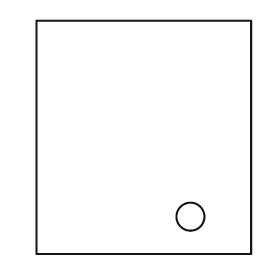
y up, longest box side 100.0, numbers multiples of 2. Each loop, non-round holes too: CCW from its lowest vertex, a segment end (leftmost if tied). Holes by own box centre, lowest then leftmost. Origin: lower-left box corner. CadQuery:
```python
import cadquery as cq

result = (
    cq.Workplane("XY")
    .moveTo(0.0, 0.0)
    .lineTo(92.0, 0.0)
    .lineTo(92.0, 100.0)
    .lineTo(0.0, 100.0)
    .close()
    .moveTo(66.0, 16.0)
    .circle(6.0)
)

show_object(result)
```